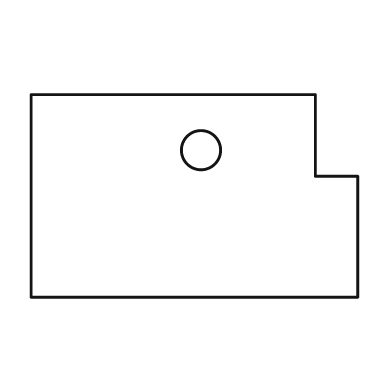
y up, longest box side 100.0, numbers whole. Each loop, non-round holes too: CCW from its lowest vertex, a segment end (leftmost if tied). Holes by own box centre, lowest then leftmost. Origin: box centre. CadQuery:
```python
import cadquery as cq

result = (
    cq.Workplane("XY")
    .moveTo(-50.0, -31.0)
    .lineTo(50.0, -31.0)
    .lineTo(50.0, 6.0)
    .lineTo(37.0, 6.0)
    .lineTo(37.0, 31.0)
    .lineTo(-50.0, 31.0)
    .close()
    .moveTo(2.0, 14.0)
    .circle(6.0)
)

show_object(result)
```